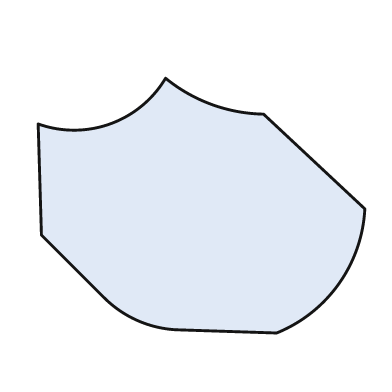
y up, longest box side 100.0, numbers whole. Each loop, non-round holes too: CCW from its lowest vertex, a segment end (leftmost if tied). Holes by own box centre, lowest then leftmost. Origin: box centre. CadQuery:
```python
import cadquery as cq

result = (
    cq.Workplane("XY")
    .moveTo(23.0, -39.0)
    .threePointArc((42.0, -24.0), (50.0, -1.0))
    .lineTo(19.0, 28.0)
    .threePointArc((3.0, 31.0), (-11.0, 39.0))
    .threePointArc((-28.0, 25.0), (-50.0, 25.0))
    .lineTo(-49.0, -9.0)
    .lineTo(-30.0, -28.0)
    .threePointArc((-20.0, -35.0), (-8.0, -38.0))
    .close()
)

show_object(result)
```